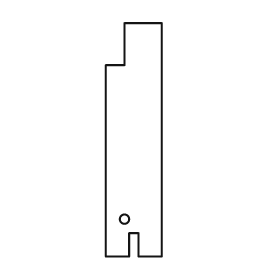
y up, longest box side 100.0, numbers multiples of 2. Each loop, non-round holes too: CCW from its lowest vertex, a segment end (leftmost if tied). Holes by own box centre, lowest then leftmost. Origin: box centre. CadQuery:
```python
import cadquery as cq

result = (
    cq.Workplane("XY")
    .moveTo(-12.0, -50.0)
    .lineTo(-2.0, -50.0)
    .lineTo(-2.0, -40.0)
    .lineTo(2.0, -40.0)
    .lineTo(2.0, -50.0)
    .lineTo(12.0, -50.0)
    .lineTo(12.0, 50.0)
    .lineTo(-4.0, 50.0)
    .lineTo(-4.0, 32.0)
    .lineTo(-12.0, 32.0)
    .close()
    .moveTo(-4.0, -34.0)
    .circle(2.0)
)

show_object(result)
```